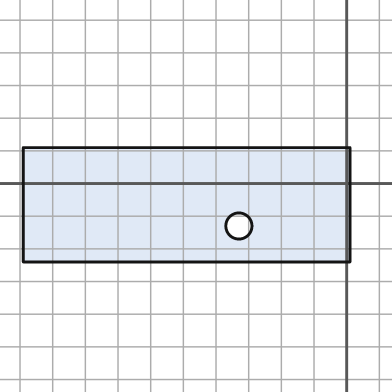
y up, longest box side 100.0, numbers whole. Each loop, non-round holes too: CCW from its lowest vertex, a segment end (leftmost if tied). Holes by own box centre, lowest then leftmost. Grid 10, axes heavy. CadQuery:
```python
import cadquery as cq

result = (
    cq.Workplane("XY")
    .moveTo(-99.0, -24.0)
    .lineTo(1.0, -24.0)
    .lineTo(1.0, 11.0)
    .lineTo(-99.0, 11.0)
    .close()
    .moveTo(-33.0, -13.0)
    .circle(4.0)
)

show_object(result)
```